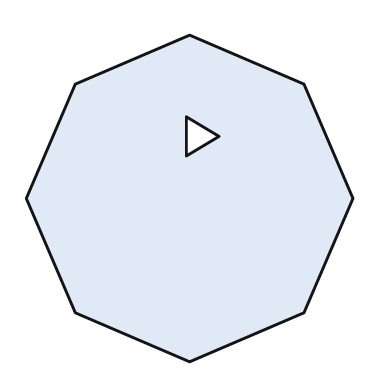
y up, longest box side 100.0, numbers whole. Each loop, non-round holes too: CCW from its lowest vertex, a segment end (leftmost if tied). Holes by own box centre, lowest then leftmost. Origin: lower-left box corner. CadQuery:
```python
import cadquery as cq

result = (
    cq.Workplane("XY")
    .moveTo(50.0, 0.0)
    .lineTo(85.0, 15.0)
    .lineTo(100.0, 50.0)
    .lineTo(85.0, 85.0)
    .lineTo(50.0, 100.0)
    .lineTo(15.0, 85.0)
    .lineTo(0.0, 50.0)
    .lineTo(15.0, 15.0)
    .close()
    .moveTo(49.0, 63.0)
    .lineTo(59.0, 69.0)
    .lineTo(49.0, 75.0)
    .close()
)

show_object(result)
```